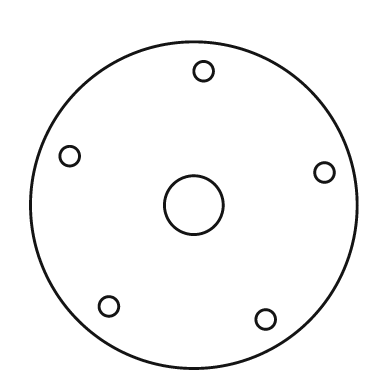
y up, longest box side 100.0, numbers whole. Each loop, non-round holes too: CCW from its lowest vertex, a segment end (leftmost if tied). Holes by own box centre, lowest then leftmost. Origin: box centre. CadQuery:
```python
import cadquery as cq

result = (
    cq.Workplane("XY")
    .moveTo(0.0, 0.0)
    .circle(50.0)
    .moveTo(22.0, -35.0)
    .circle(3.0)
    .moveTo(-26.0, -31.0)
    .circle(3.0)
    .moveTo(0.0, 0.0)
    .circle(9.0)
    .moveTo(40.0, 10.0)
    .circle(3.0)
    .moveTo(-38.0, 15.0)
    .circle(3.0)
    .moveTo(3.0, 41.0)
    .circle(3.0)
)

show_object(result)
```